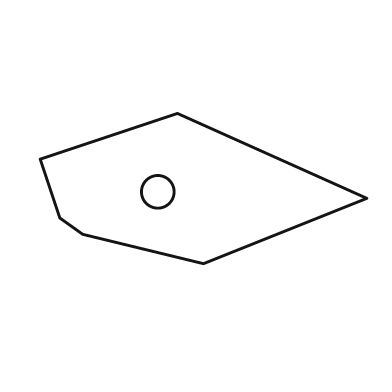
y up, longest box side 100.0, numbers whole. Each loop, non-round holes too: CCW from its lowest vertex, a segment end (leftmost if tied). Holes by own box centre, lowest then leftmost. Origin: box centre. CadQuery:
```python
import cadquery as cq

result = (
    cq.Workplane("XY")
    .moveTo(0.0, -23.0)
    .lineTo(50.0, -3.0)
    .lineTo(-8.0, 23.0)
    .lineTo(-50.0, 9.0)
    .lineTo(-44.0, -9.0)
    .lineTo(-37.0, -14.0)
    .close()
    .moveTo(-14.0, -1.0)
    .circle(5.0)
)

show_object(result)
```